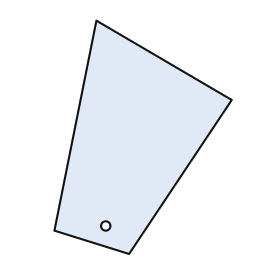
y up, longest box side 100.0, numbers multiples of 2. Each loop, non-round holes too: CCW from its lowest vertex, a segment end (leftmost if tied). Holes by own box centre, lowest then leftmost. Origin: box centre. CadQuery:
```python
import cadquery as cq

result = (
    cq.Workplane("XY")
    .moveTo(-6.0, -50.0)
    .lineTo(38.0, 16.0)
    .lineTo(-20.0, 50.0)
    .lineTo(-38.0, -40.0)
    .close()
    .moveTo(-16.0, -38.0)
    .circle(2.0)
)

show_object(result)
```